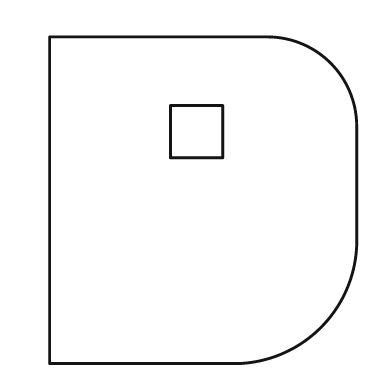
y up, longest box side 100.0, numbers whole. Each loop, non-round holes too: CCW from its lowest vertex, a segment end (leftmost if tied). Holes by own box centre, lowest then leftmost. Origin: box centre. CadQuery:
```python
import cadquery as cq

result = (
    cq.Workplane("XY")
    .moveTo(-47.0, -50.0)
    .lineTo(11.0, -50.0)
    .threePointArc((36.0, -39.0), (47.0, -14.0))
    .lineTo(47.0, 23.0)
    .threePointArc((39.0, 42.0), (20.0, 50.0))
    .lineTo(-47.0, 50.0)
    .close()
    .moveTo(-10.0, 13.0)
    .lineTo(6.0, 13.0)
    .lineTo(6.0, 29.0)
    .lineTo(-10.0, 29.0)
    .close()
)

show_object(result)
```